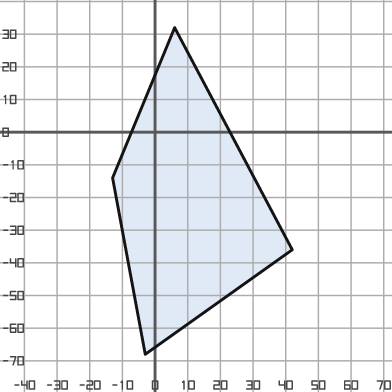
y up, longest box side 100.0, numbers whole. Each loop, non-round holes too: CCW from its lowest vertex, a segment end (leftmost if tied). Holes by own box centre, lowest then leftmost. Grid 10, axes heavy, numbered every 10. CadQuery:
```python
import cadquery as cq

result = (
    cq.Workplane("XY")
    .moveTo(-3.0, -68.0)
    .lineTo(42.0, -36.0)
    .lineTo(6.0, 32.0)
    .lineTo(-13.0, -14.0)
    .close()
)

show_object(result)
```